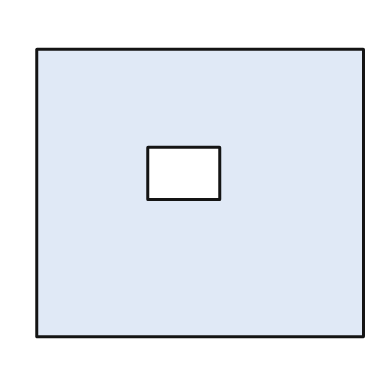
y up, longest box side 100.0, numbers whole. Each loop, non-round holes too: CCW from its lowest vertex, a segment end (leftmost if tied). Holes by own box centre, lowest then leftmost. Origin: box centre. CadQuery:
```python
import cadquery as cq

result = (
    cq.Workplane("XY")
    .moveTo(-50.0, -44.0)
    .lineTo(50.0, -44.0)
    .lineTo(50.0, 44.0)
    .lineTo(-50.0, 44.0)
    .close()
    .moveTo(-16.0, -2.0)
    .lineTo(6.0, -2.0)
    .lineTo(6.0, 14.0)
    .lineTo(-16.0, 14.0)
    .close()
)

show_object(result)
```